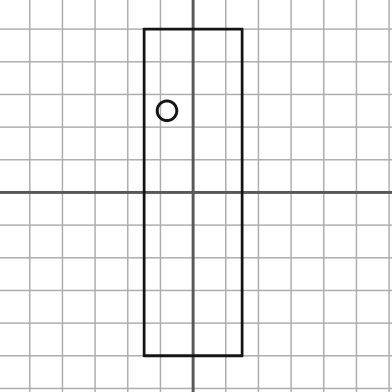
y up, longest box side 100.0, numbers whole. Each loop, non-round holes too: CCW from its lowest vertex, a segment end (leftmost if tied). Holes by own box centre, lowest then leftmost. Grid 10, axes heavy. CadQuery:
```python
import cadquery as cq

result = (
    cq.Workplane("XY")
    .moveTo(-15.0, -50.0)
    .lineTo(15.0, -50.0)
    .lineTo(15.0, 50.0)
    .lineTo(-15.0, 50.0)
    .close()
    .moveTo(-8.0, 25.0)
    .circle(3.0)
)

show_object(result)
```